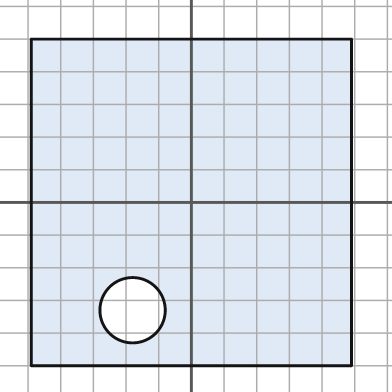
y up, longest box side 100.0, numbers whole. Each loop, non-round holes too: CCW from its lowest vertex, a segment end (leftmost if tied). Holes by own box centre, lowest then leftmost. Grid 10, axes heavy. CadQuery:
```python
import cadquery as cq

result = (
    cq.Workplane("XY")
    .moveTo(-49.0, -50.0)
    .lineTo(49.0, -50.0)
    .lineTo(49.0, 50.0)
    .lineTo(-49.0, 50.0)
    .close()
    .moveTo(-18.0, -33.0)
    .circle(10.0)
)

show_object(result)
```